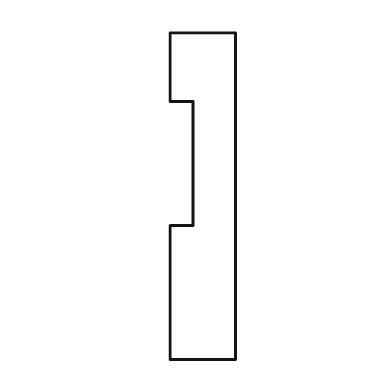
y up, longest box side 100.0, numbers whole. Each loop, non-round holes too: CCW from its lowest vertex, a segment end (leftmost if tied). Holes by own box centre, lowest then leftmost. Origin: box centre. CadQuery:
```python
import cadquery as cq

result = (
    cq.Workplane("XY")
    .moveTo(-10.0, -50.0)
    .lineTo(10.0, -50.0)
    .lineTo(10.0, 50.0)
    .lineTo(-10.0, 50.0)
    .lineTo(-10.0, 29.0)
    .lineTo(-3.0, 29.0)
    .lineTo(-3.0, -9.0)
    .lineTo(-10.0, -9.0)
    .close()
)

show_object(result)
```